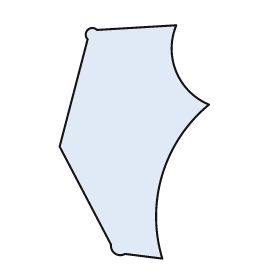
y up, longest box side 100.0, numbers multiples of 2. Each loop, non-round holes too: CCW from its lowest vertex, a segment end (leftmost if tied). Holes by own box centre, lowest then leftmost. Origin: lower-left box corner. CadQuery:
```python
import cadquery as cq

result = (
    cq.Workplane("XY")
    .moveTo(44.0, 0.0)
    .threePointArc((44.0, 36.0), (64.0, 66.0))
    .threePointArc((50.0, 80.0), (50.0, 100.0))
    .lineTo(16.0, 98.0)
    .threePointArc((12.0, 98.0), (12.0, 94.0))
    .lineTo(0.0, 48.0)
    .lineTo(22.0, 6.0)
    .threePointArc((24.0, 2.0), (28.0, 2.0))
    .close()
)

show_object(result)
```